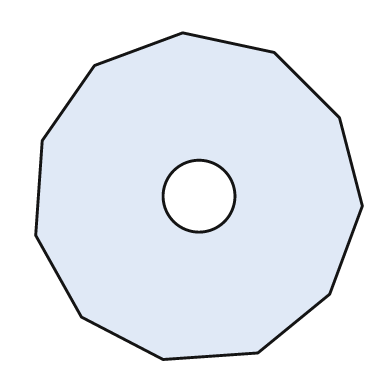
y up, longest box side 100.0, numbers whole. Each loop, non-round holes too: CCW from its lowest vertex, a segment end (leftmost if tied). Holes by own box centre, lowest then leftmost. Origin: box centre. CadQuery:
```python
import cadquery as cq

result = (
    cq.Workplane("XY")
    .moveTo(-11.0, -50.0)
    .lineTo(18.0, -48.0)
    .lineTo(40.0, -30.0)
    .lineTo(50.0, -3.0)
    .lineTo(43.0, 24.0)
    .lineTo(23.0, 44.0)
    .lineTo(-5.0, 50.0)
    .lineTo(-32.0, 40.0)
    .lineTo(-48.0, 17.0)
    .lineTo(-50.0, -12.0)
    .lineTo(-36.0, -37.0)
    .close()
    .moveTo(0.0, 0.0)
    .circle(11.0)
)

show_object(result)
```